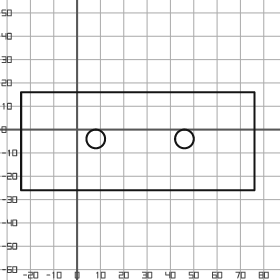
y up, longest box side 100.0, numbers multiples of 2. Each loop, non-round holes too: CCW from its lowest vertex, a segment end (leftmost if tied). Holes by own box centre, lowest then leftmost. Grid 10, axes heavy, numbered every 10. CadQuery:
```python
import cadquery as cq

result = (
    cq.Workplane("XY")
    .moveTo(-24.0, -26.0)
    .lineTo(76.0, -26.0)
    .lineTo(76.0, 16.0)
    .lineTo(-24.0, 16.0)
    .close()
    .moveTo(8.0, -4.0)
    .circle(4.0)
    .moveTo(46.0, -4.0)
    .circle(4.0)
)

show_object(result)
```